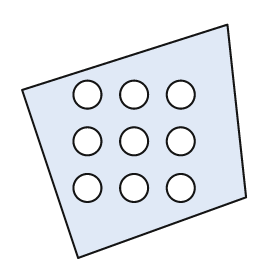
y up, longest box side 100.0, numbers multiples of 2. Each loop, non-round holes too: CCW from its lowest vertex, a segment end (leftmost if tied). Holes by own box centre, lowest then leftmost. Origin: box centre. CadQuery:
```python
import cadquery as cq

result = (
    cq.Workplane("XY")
    .moveTo(-24.0, -50.0)
    .lineTo(48.0, -24.0)
    .lineTo(40.0, 50.0)
    .lineTo(-48.0, 22.0)
    .close()
    .moveTo(-20.0, -20.0)
    .circle(6.0)
    .moveTo(0.0, -20.0)
    .circle(6.0)
    .moveTo(20.0, -20.0)
    .circle(6.0)
    .moveTo(-20.0, 0.0)
    .circle(6.0)
    .moveTo(0.0, 0.0)
    .circle(6.0)
    .moveTo(20.0, 0.0)
    .circle(6.0)
    .moveTo(-20.0, 20.0)
    .circle(6.0)
    .moveTo(0.0, 20.0)
    .circle(6.0)
    .moveTo(20.0, 20.0)
    .circle(6.0)
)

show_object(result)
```